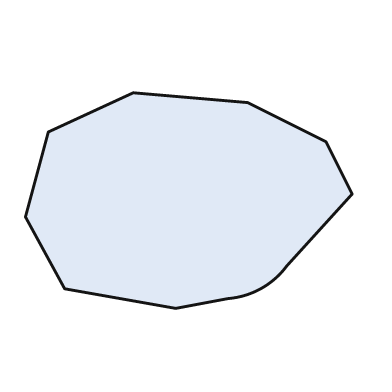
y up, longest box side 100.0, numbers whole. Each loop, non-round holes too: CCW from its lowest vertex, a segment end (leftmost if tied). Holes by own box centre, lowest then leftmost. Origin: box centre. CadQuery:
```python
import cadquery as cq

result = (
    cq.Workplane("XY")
    .moveTo(-4.0, -33.0)
    .lineTo(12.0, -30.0)
    .threePointArc((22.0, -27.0), (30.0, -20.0))
    .lineTo(50.0, 2.0)
    .lineTo(42.0, 18.0)
    .lineTo(18.0, 30.0)
    .lineTo(-17.0, 33.0)
    .lineTo(-43.0, 21.0)
    .lineTo(-50.0, -5.0)
    .lineTo(-38.0, -27.0)
    .close()
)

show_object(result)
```